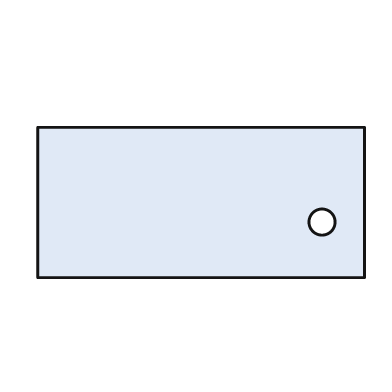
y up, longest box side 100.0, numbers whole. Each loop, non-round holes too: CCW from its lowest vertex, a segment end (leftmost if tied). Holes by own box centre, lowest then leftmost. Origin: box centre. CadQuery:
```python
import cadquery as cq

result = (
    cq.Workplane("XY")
    .moveTo(-50.0, -23.0)
    .lineTo(50.0, -23.0)
    .lineTo(50.0, 23.0)
    .lineTo(-50.0, 23.0)
    .close()
    .moveTo(37.0, -6.0)
    .circle(4.0)
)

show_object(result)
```